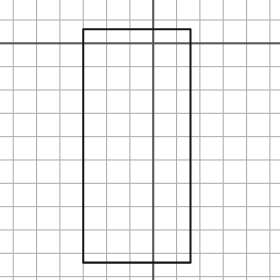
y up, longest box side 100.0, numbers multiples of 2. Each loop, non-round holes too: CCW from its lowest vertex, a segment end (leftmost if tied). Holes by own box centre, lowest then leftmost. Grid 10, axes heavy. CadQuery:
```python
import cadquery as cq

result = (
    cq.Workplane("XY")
    .moveTo(-30.0, -94.0)
    .lineTo(16.0, -94.0)
    .lineTo(16.0, 6.0)
    .lineTo(-30.0, 6.0)
    .close()
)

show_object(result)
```